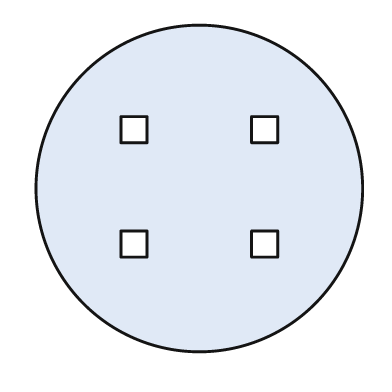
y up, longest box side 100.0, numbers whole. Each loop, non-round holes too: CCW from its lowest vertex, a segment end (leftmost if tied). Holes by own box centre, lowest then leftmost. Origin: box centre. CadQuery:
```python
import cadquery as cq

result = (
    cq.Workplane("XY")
    .moveTo(0.0, 0.0)
    .circle(50.0)
    .moveTo(-24.0, -21.0)
    .lineTo(-16.0, -21.0)
    .lineTo(-16.0, -13.0)
    .lineTo(-24.0, -13.0)
    .close()
    .moveTo(16.0, -21.0)
    .lineTo(24.0, -21.0)
    .lineTo(24.0, -13.0)
    .lineTo(16.0, -13.0)
    .close()
    .moveTo(-24.0, 14.0)
    .lineTo(-16.0, 14.0)
    .lineTo(-16.0, 22.0)
    .lineTo(-24.0, 22.0)
    .close()
    .moveTo(16.0, 14.0)
    .lineTo(24.0, 14.0)
    .lineTo(24.0, 22.0)
    .lineTo(16.0, 22.0)
    .close()
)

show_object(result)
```